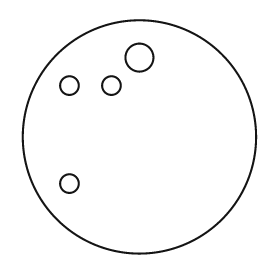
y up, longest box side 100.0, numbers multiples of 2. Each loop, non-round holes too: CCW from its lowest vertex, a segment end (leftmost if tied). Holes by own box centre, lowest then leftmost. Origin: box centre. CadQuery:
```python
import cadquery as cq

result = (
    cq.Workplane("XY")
    .moveTo(0.0, 0.0)
    .circle(50.0)
    .moveTo(-30.0, -20.0)
    .circle(4.0)
    .moveTo(-30.0, 22.0)
    .circle(4.0)
    .moveTo(-12.0, 22.0)
    .circle(4.0)
    .moveTo(0.0, 34.0)
    .circle(6.0)
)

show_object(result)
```